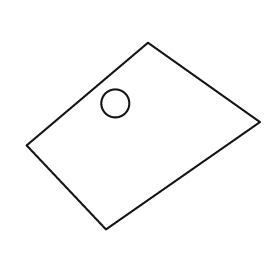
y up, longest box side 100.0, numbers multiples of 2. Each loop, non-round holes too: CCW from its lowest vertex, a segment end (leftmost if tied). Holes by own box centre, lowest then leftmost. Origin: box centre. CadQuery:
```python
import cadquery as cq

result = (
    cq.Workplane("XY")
    .moveTo(-16.0, -40.0)
    .lineTo(50.0, 6.0)
    .lineTo(2.0, 40.0)
    .lineTo(-50.0, -4.0)
    .close()
    .moveTo(-12.0, 14.0)
    .circle(6.0)
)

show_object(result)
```